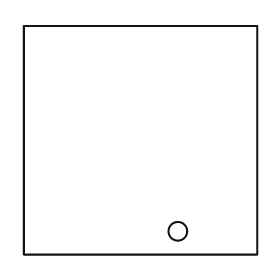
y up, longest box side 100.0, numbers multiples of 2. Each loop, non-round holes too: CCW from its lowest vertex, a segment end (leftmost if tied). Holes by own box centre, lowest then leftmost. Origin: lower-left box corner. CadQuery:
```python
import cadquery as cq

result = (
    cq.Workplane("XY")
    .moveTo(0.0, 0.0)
    .lineTo(100.0, 0.0)
    .lineTo(100.0, 98.0)
    .lineTo(0.0, 98.0)
    .close()
    .moveTo(66.0, 10.0)
    .circle(4.0)
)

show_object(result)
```